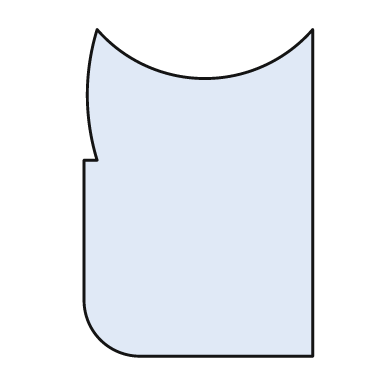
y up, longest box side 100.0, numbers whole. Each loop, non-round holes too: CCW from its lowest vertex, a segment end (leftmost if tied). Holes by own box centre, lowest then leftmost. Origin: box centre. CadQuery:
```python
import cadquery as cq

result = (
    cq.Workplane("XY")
    .moveTo(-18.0, -50.0)
    .lineTo(35.0, -50.0)
    .lineTo(35.0, 50.0)
    .threePointArc((2.0, 35.0), (-31.0, 50.0))
    .threePointArc((-34.0, 30.0), (-31.0, 10.0))
    .lineTo(-35.0, 10.0)
    .lineTo(-35.0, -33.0)
    .threePointArc((-30.0, -45.0), (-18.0, -50.0))
    .close()
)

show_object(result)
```